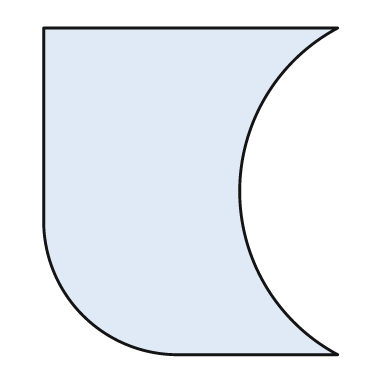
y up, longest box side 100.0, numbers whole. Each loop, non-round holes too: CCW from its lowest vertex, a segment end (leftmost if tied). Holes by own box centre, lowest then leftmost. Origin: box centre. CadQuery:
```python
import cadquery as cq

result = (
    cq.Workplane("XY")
    .moveTo(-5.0, -50.0)
    .lineTo(45.0, -50.0)
    .threePointArc((15.0, 0.0), (45.0, 50.0))
    .lineTo(-45.0, 50.0)
    .lineTo(-45.0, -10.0)
    .threePointArc((-33.0, -38.0), (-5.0, -50.0))
    .close()
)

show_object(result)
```